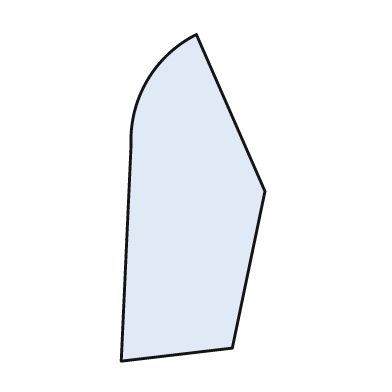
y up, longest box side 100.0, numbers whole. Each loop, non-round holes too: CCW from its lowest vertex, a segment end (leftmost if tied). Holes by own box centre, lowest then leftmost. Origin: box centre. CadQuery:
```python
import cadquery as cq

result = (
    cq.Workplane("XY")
    .moveTo(-22.0, -50.0)
    .lineTo(12.0, -46.0)
    .lineTo(22.0, 2.0)
    .lineTo(1.0, 50.0)
    .threePointArc((-14.0, 36.0), (-19.0, 16.0))
    .close()
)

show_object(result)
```